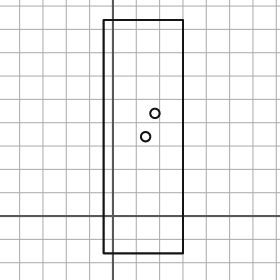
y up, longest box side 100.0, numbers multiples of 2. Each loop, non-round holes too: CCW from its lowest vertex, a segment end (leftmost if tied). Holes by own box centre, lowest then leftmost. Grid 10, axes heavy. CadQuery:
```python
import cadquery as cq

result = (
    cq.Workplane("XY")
    .moveTo(-4.0, -16.0)
    .lineTo(30.0, -16.0)
    .lineTo(30.0, 84.0)
    .lineTo(-4.0, 84.0)
    .close()
    .moveTo(14.0, 34.0)
    .circle(2.0)
    .moveTo(18.0, 44.0)
    .circle(2.0)
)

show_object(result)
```